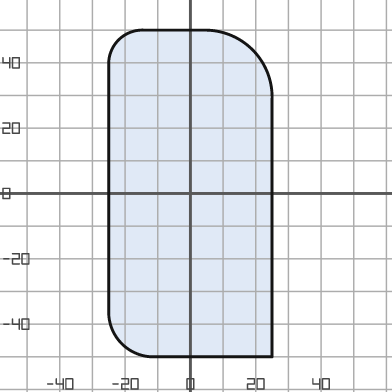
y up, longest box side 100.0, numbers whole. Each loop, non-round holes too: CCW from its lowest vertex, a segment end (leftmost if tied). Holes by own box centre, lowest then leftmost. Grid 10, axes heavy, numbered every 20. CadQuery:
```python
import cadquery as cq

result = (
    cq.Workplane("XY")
    .moveTo(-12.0, -50.0)
    .lineTo(25.0, -50.0)
    .lineTo(25.0, 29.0)
    .threePointArc((19.0, 44.0), (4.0, 50.0))
    .lineTo(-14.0, 50.0)
    .threePointArc((-22.0, 47.0), (-25.0, 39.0))
    .lineTo(-25.0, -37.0)
    .threePointArc((-21.0, -46.0), (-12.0, -50.0))
    .close()
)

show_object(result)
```